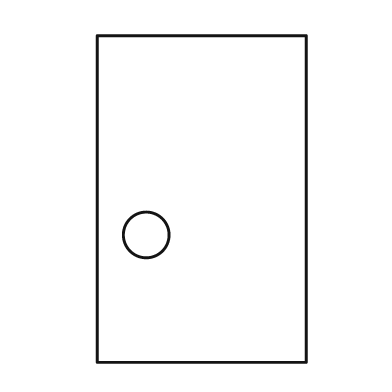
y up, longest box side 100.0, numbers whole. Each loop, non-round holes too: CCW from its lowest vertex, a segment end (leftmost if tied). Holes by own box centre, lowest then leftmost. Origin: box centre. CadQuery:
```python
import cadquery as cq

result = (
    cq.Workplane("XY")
    .moveTo(-32.0, -50.0)
    .lineTo(32.0, -50.0)
    .lineTo(32.0, 50.0)
    .lineTo(-32.0, 50.0)
    .close()
    .moveTo(-17.0, -11.0)
    .circle(7.0)
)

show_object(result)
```